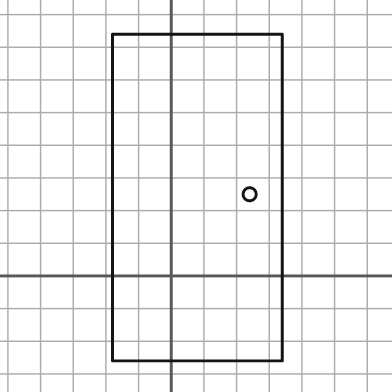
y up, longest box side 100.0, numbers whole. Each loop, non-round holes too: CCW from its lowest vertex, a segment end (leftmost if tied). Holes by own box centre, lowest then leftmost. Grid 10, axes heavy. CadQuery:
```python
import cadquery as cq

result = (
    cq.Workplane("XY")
    .moveTo(-18.0, -26.0)
    .lineTo(34.0, -26.0)
    .lineTo(34.0, 74.0)
    .lineTo(-18.0, 74.0)
    .close()
    .moveTo(24.0, 25.0)
    .circle(2.0)
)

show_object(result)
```